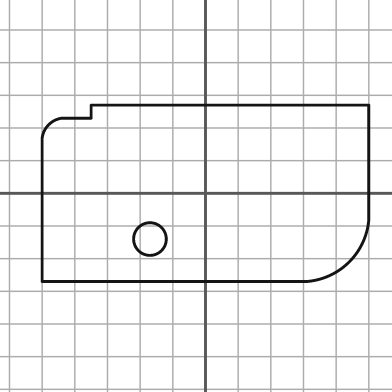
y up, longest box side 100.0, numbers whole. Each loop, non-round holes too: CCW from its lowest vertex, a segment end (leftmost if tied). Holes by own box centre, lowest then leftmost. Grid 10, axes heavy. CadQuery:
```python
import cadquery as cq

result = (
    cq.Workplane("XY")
    .moveTo(-50.0, -27.0)
    .lineTo(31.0, -27.0)
    .threePointArc((44.0, -21.0), (50.0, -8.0))
    .lineTo(50.0, 27.0)
    .lineTo(-35.0, 27.0)
    .lineTo(-35.0, 23.0)
    .lineTo(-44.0, 23.0)
    .threePointArc((-48.0, 21.0), (-50.0, 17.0))
    .close()
    .moveTo(-17.0, -14.0)
    .circle(5.0)
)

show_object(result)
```